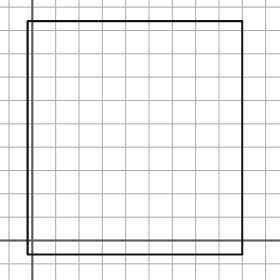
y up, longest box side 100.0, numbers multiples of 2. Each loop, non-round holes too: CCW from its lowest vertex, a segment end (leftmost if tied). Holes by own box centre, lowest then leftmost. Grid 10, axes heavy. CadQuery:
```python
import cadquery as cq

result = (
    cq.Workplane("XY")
    .moveTo(-2.0, -6.0)
    .lineTo(90.0, -6.0)
    .lineTo(90.0, 94.0)
    .lineTo(-2.0, 94.0)
    .close()
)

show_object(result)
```